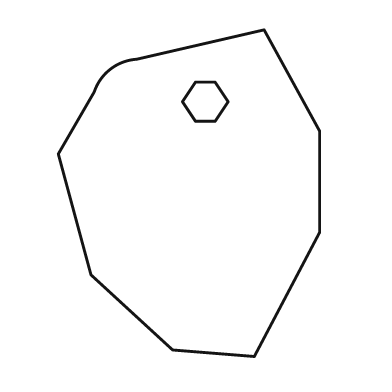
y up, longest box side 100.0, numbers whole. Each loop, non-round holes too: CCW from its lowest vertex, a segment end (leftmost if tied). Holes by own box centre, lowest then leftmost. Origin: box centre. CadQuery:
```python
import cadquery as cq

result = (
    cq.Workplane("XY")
    .moveTo(20.0, -50.0)
    .lineTo(40.0, -12.0)
    .lineTo(40.0, 19.0)
    .lineTo(23.0, 50.0)
    .lineTo(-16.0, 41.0)
    .threePointArc((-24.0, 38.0), (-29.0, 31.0))
    .lineTo(-40.0, 12.0)
    .lineTo(-30.0, -25.0)
    .lineTo(-5.0, -48.0)
    .close()
    .moveTo(2.0, 22.0)
    .lineTo(8.0, 22.0)
    .lineTo(12.0, 28.0)
    .lineTo(8.0, 34.0)
    .lineTo(2.0, 34.0)
    .lineTo(-2.0, 28.0)
    .close()
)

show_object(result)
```